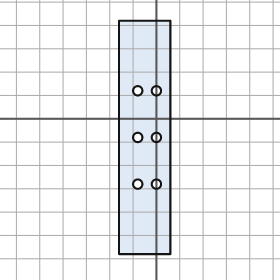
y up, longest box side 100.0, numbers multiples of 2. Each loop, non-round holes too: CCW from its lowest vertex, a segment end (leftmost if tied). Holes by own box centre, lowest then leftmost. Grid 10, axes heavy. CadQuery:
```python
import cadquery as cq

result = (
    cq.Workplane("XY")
    .moveTo(-16.0, -58.0)
    .lineTo(6.0, -58.0)
    .lineTo(6.0, 42.0)
    .lineTo(-16.0, 42.0)
    .close()
    .moveTo(-8.0, -28.0)
    .circle(2.0)
    .moveTo(0.0, -28.0)
    .circle(2.0)
    .moveTo(-8.0, -8.0)
    .circle(2.0)
    .moveTo(0.0, -8.0)
    .circle(2.0)
    .moveTo(-8.0, 12.0)
    .circle(2.0)
    .moveTo(0.0, 12.0)
    .circle(2.0)
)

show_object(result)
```